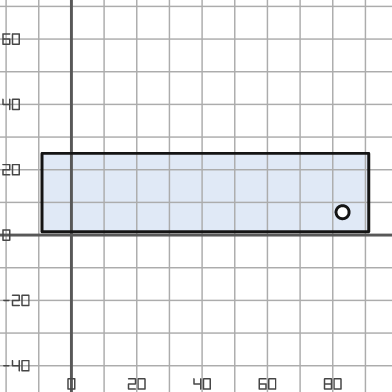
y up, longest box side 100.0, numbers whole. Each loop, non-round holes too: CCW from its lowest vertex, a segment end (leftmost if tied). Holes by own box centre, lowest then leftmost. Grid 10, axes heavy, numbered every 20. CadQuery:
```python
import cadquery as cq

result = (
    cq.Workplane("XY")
    .moveTo(-9.0, 1.0)
    .lineTo(91.0, 1.0)
    .lineTo(91.0, 25.0)
    .lineTo(-9.0, 25.0)
    .close()
    .moveTo(83.0, 7.0)
    .circle(2.0)
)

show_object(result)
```